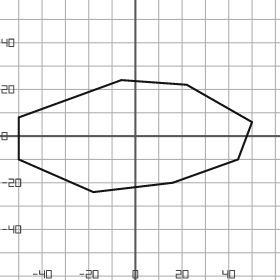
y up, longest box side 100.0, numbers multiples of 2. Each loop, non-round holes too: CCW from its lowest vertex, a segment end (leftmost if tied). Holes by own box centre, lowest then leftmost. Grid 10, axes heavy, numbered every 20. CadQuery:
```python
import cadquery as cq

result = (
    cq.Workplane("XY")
    .moveTo(-18.0, -24.0)
    .lineTo(16.0, -20.0)
    .lineTo(44.0, -10.0)
    .lineTo(50.0, 6.0)
    .lineTo(22.0, 22.0)
    .lineTo(-6.0, 24.0)
    .lineTo(-50.0, 8.0)
    .lineTo(-50.0, -10.0)
    .close()
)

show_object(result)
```